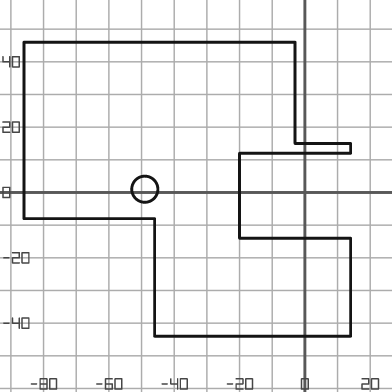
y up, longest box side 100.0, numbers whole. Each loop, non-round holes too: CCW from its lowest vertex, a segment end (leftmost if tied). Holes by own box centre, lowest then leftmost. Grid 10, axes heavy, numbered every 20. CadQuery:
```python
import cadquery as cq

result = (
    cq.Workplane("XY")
    .moveTo(-46.0, -44.0)
    .lineTo(14.0, -44.0)
    .lineTo(14.0, -14.0)
    .lineTo(-20.0, -14.0)
    .lineTo(-20.0, 12.0)
    .lineTo(14.0, 12.0)
    .lineTo(14.0, 15.0)
    .lineTo(-3.0, 15.0)
    .lineTo(-3.0, 46.0)
    .lineTo(-86.0, 46.0)
    .lineTo(-86.0, -8.0)
    .lineTo(-46.0, -8.0)
    .close()
    .moveTo(-49.0, 1.0)
    .circle(4.0)
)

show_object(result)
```